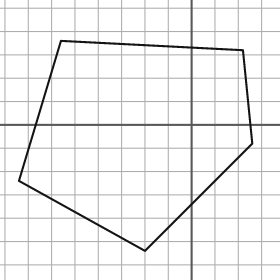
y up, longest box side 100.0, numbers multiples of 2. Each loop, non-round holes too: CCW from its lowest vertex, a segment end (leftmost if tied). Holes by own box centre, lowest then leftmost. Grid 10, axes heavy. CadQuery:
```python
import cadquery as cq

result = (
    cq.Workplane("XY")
    .moveTo(-20.0, -54.0)
    .lineTo(26.0, -8.0)
    .lineTo(22.0, 32.0)
    .lineTo(-56.0, 36.0)
    .lineTo(-74.0, -24.0)
    .close()
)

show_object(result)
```